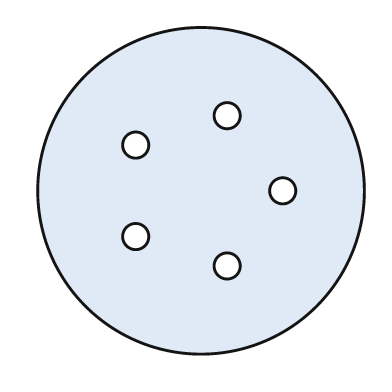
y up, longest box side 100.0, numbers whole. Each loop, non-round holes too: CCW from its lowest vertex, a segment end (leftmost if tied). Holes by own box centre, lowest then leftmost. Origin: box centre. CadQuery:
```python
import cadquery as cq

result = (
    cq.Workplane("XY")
    .moveTo(0.0, 0.0)
    .circle(50.0)
    .moveTo(8.0, -23.0)
    .circle(4.0)
    .moveTo(-20.0, -14.0)
    .circle(4.0)
    .moveTo(25.0, 0.0)
    .circle(4.0)
    .moveTo(-20.0, 14.0)
    .circle(4.0)
    .moveTo(8.0, 23.0)
    .circle(4.0)
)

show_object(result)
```